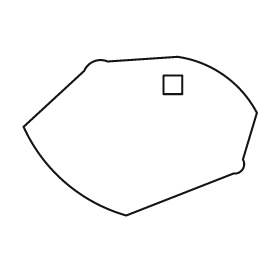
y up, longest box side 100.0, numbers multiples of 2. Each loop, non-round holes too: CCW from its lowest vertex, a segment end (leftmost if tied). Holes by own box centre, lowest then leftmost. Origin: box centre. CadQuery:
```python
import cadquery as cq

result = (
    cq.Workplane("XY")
    .moveTo(-6.0, -34.0)
    .lineTo(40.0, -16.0)
    .threePointArc((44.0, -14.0), (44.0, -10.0))
    .lineTo(50.0, 10.0)
    .threePointArc((36.0, 26.0), (16.0, 34.0))
    .lineTo(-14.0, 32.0)
    .threePointArc((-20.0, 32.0), (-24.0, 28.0))
    .lineTo(-50.0, 4.0)
    .threePointArc((-32.0, -20.0), (-6.0, -34.0))
    .close()
    .moveTo(10.0, 18.0)
    .lineTo(18.0, 18.0)
    .lineTo(18.0, 26.0)
    .lineTo(10.0, 26.0)
    .close()
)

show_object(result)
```